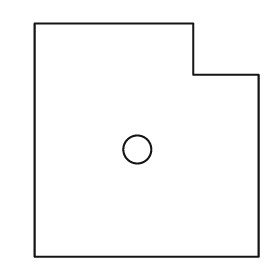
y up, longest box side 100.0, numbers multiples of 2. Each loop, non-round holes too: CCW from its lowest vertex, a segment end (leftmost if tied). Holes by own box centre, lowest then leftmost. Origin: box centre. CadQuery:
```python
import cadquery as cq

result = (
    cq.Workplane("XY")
    .moveTo(-48.0, -50.0)
    .lineTo(48.0, -50.0)
    .lineTo(48.0, 28.0)
    .lineTo(20.0, 28.0)
    .lineTo(20.0, 50.0)
    .lineTo(-48.0, 50.0)
    .close()
    .moveTo(-4.0, -4.0)
    .circle(6.0)
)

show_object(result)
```